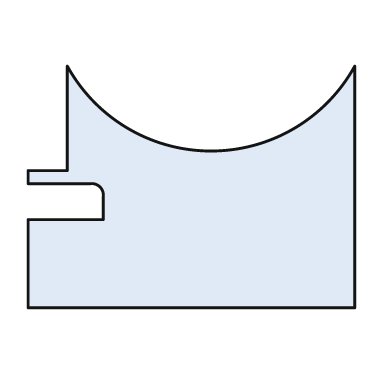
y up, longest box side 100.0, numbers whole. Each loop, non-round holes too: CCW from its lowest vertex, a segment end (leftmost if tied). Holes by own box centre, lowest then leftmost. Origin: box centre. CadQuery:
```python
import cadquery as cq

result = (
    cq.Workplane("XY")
    .moveTo(-50.0, -37.0)
    .lineTo(50.0, -37.0)
    .lineTo(50.0, 37.0)
    .threePointArc((6.0, 11.0), (-38.0, 37.0))
    .lineTo(-38.0, 5.0)
    .lineTo(-50.0, 5.0)
    .lineTo(-50.0, 1.0)
    .lineTo(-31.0, 1.0)
    .threePointArc((-28.0, 0.0), (-27.0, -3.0))
    .lineTo(-27.0, -10.0)
    .lineTo(-50.0, -10.0)
    .close()
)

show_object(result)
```